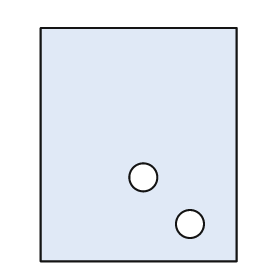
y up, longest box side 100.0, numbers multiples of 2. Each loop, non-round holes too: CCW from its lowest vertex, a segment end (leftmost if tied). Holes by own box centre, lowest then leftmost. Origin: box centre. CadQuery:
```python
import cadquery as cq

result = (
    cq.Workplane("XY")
    .moveTo(-42.0, -50.0)
    .lineTo(42.0, -50.0)
    .lineTo(42.0, 50.0)
    .lineTo(-42.0, 50.0)
    .close()
    .moveTo(22.0, -34.0)
    .circle(6.0)
    .moveTo(2.0, -14.0)
    .circle(6.0)
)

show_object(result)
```